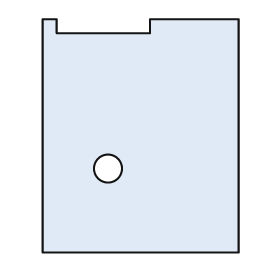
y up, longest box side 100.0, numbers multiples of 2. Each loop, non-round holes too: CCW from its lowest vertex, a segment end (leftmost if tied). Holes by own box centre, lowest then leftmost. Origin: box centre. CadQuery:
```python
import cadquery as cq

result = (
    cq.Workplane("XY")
    .moveTo(-42.0, -50.0)
    .lineTo(42.0, -50.0)
    .lineTo(42.0, 50.0)
    .lineTo(4.0, 50.0)
    .lineTo(4.0, 44.0)
    .lineTo(-36.0, 44.0)
    .lineTo(-36.0, 50.0)
    .lineTo(-42.0, 50.0)
    .close()
    .moveTo(-14.0, -14.0)
    .circle(6.0)
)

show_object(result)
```